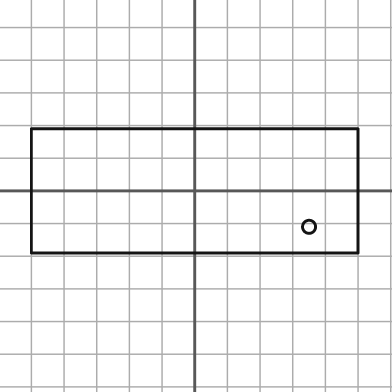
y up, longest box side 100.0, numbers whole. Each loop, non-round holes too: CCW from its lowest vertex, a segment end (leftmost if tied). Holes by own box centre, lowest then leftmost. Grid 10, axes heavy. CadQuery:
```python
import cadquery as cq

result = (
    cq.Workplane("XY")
    .moveTo(-50.0, -19.0)
    .lineTo(50.0, -19.0)
    .lineTo(50.0, 19.0)
    .lineTo(-50.0, 19.0)
    .close()
    .moveTo(35.0, -11.0)
    .circle(2.0)
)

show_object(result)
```